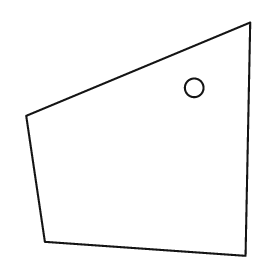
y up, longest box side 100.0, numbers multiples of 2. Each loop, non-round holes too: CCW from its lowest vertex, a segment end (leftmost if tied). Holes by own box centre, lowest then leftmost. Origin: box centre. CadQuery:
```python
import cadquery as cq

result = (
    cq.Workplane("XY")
    .moveTo(46.0, -50.0)
    .lineTo(48.0, 50.0)
    .lineTo(-48.0, 10.0)
    .lineTo(-40.0, -44.0)
    .close()
    .moveTo(24.0, 22.0)
    .circle(4.0)
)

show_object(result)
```